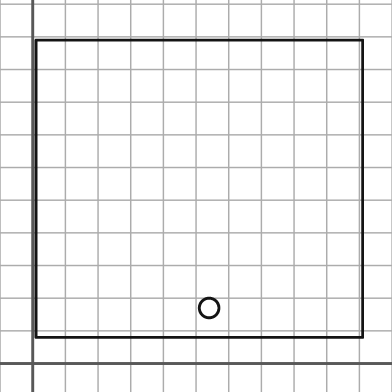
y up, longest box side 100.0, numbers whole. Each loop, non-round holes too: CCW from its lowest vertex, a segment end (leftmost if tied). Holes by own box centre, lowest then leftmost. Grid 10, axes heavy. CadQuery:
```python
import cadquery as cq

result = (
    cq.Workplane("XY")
    .moveTo(1.0, 8.0)
    .lineTo(101.0, 8.0)
    .lineTo(101.0, 99.0)
    .lineTo(1.0, 99.0)
    .close()
    .moveTo(54.0, 17.0)
    .circle(3.0)
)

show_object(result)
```